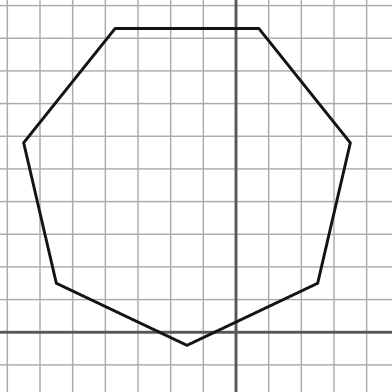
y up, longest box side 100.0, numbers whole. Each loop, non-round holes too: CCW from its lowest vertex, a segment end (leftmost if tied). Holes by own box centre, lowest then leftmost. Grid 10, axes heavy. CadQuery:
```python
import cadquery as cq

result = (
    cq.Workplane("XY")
    .moveTo(-15.0, -4.0)
    .lineTo(25.0, 15.0)
    .lineTo(35.0, 58.0)
    .lineTo(7.0, 93.0)
    .lineTo(-37.0, 93.0)
    .lineTo(-65.0, 58.0)
    .lineTo(-55.0, 15.0)
    .close()
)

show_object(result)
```